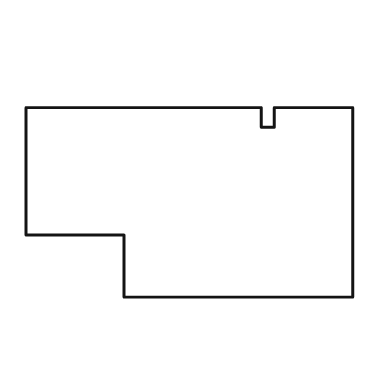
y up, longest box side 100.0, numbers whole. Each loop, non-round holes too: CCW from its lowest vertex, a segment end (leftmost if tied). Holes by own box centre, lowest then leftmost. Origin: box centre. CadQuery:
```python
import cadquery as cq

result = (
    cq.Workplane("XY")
    .moveTo(-20.0, -29.0)
    .lineTo(50.0, -29.0)
    .lineTo(50.0, 29.0)
    .lineTo(26.0, 29.0)
    .lineTo(26.0, 23.0)
    .lineTo(22.0, 23.0)
    .lineTo(22.0, 29.0)
    .lineTo(-50.0, 29.0)
    .lineTo(-50.0, -10.0)
    .lineTo(-20.0, -10.0)
    .close()
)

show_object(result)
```